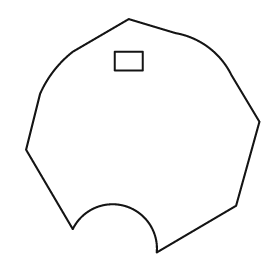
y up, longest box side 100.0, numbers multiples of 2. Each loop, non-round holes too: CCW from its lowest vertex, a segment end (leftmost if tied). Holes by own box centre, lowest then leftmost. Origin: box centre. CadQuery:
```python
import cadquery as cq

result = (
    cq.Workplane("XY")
    .moveTo(6.0, -50.0)
    .lineTo(40.0, -30.0)
    .lineTo(50.0, 6.0)
    .lineTo(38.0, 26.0)
    .threePointArc((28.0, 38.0), (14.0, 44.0))
    .lineTo(-6.0, 50.0)
    .lineTo(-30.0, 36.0)
    .threePointArc((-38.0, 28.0), (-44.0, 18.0))
    .lineTo(-50.0, -6.0)
    .lineTo(-30.0, -40.0)
    .threePointArc((-8.0, -30.0), (6.0, -50.0))
    .close()
    .moveTo(-12.0, 28.0)
    .lineTo(0.0, 28.0)
    .lineTo(0.0, 36.0)
    .lineTo(-12.0, 36.0)
    .close()
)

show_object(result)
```